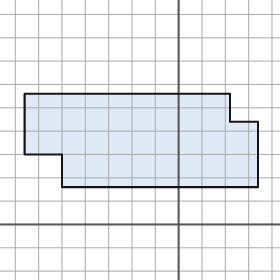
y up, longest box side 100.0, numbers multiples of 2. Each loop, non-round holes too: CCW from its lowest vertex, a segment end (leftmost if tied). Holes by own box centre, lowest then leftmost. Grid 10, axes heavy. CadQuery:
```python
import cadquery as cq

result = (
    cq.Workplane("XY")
    .moveTo(-50.0, 16.0)
    .lineTo(34.0, 16.0)
    .lineTo(34.0, 44.0)
    .lineTo(22.0, 44.0)
    .lineTo(22.0, 56.0)
    .lineTo(-66.0, 56.0)
    .lineTo(-66.0, 30.0)
    .lineTo(-50.0, 30.0)
    .close()
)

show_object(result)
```